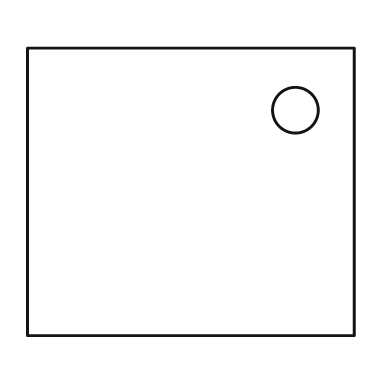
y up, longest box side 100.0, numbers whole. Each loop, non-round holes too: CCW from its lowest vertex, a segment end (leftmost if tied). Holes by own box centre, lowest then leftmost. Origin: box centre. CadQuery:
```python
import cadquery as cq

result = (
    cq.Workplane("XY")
    .moveTo(-50.0, -44.0)
    .lineTo(50.0, -44.0)
    .lineTo(50.0, 44.0)
    .lineTo(-50.0, 44.0)
    .close()
    .moveTo(32.0, 25.0)
    .circle(7.0)
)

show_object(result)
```